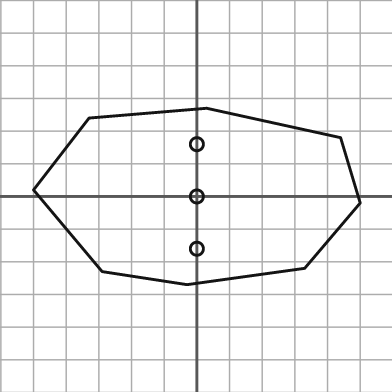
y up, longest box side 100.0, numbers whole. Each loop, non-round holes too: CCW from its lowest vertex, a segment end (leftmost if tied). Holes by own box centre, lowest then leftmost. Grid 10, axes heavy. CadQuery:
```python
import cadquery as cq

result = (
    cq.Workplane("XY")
    .moveTo(-3.0, -27.0)
    .lineTo(33.0, -22.0)
    .lineTo(50.0, -2.0)
    .lineTo(44.0, 18.0)
    .lineTo(3.0, 27.0)
    .lineTo(-33.0, 24.0)
    .lineTo(-50.0, 2.0)
    .lineTo(-29.0, -23.0)
    .close()
    .moveTo(0.0, -16.0)
    .circle(2.0)
    .moveTo(0.0, 0.0)
    .circle(2.0)
    .moveTo(0.0, 16.0)
    .circle(2.0)
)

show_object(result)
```